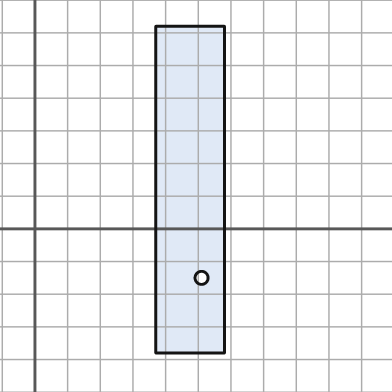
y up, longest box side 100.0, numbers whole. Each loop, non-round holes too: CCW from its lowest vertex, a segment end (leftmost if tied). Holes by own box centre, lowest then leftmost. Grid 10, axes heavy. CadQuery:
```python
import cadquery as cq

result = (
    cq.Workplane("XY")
    .moveTo(37.0, -38.0)
    .lineTo(58.0, -38.0)
    .lineTo(58.0, 62.0)
    .lineTo(37.0, 62.0)
    .close()
    .moveTo(51.0, -15.0)
    .circle(2.0)
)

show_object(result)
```